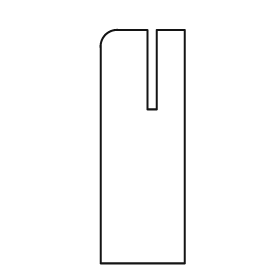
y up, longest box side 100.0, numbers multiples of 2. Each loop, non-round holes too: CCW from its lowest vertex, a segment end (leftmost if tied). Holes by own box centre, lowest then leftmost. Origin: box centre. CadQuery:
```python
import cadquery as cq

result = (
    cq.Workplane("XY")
    .moveTo(-18.0, -50.0)
    .lineTo(18.0, -50.0)
    .lineTo(18.0, 50.0)
    .lineTo(6.0, 50.0)
    .lineTo(6.0, 16.0)
    .lineTo(2.0, 16.0)
    .lineTo(2.0, 50.0)
    .lineTo(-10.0, 50.0)
    .threePointArc((-16.0, 48.0), (-18.0, 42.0))
    .close()
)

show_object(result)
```